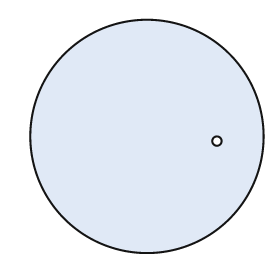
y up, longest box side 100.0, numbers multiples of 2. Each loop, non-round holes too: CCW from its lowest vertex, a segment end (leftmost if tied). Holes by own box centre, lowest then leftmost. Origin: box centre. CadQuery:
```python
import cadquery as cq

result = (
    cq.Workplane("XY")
    .moveTo(0.0, 0.0)
    .circle(50.0)
    .moveTo(30.0, -2.0)
    .circle(2.0)
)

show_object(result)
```